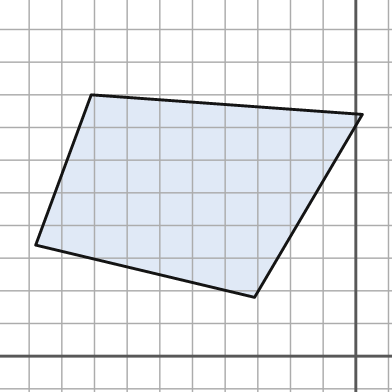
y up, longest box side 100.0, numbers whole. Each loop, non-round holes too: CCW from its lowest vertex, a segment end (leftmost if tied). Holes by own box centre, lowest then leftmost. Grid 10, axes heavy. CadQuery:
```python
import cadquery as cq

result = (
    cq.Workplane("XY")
    .moveTo(-31.0, 18.0)
    .lineTo(2.0, 74.0)
    .lineTo(-81.0, 80.0)
    .lineTo(-98.0, 34.0)
    .close()
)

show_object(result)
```